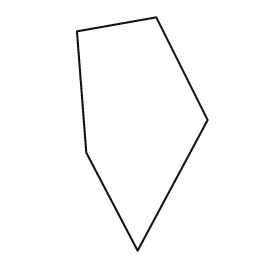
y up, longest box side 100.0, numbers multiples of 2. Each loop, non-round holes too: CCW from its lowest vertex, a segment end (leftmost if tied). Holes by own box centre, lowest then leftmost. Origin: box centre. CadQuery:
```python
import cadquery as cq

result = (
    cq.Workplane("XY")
    .moveTo(-2.0, -50.0)
    .lineTo(28.0, 6.0)
    .lineTo(6.0, 50.0)
    .lineTo(-28.0, 44.0)
    .lineTo(-24.0, -8.0)
    .close()
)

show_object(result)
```